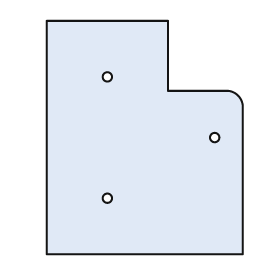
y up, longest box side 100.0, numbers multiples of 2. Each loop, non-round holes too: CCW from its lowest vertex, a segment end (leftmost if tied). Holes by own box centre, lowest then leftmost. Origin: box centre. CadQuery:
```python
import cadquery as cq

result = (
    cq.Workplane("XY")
    .moveTo(-42.0, -50.0)
    .lineTo(42.0, -50.0)
    .lineTo(42.0, 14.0)
    .threePointArc((40.0, 18.0), (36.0, 20.0))
    .lineTo(10.0, 20.0)
    .lineTo(10.0, 50.0)
    .lineTo(-42.0, 50.0)
    .close()
    .moveTo(-16.0, -26.0)
    .circle(2.0)
    .moveTo(30.0, 0.0)
    .circle(2.0)
    .moveTo(-16.0, 26.0)
    .circle(2.0)
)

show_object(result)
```